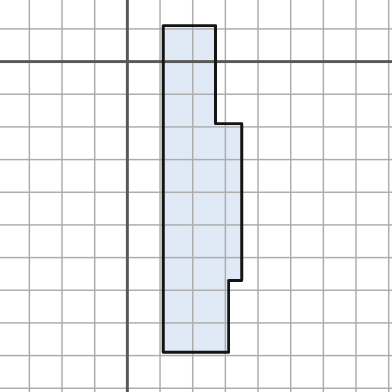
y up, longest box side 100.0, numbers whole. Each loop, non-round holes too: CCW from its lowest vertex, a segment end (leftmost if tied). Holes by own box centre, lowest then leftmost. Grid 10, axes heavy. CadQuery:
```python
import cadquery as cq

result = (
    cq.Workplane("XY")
    .moveTo(11.0, -89.0)
    .lineTo(31.0, -89.0)
    .lineTo(31.0, -67.0)
    .lineTo(35.0, -67.0)
    .lineTo(35.0, -19.0)
    .lineTo(27.0, -19.0)
    .lineTo(27.0, 11.0)
    .lineTo(11.0, 11.0)
    .close()
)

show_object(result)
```